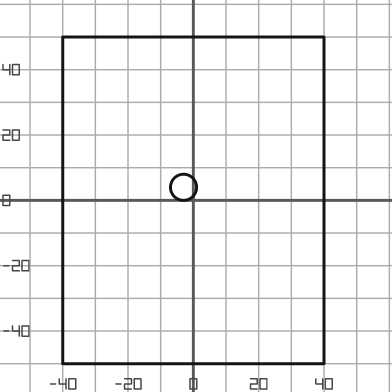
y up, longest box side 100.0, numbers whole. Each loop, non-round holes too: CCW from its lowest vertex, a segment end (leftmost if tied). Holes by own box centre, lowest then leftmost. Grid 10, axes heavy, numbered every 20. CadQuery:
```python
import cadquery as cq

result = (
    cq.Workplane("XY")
    .moveTo(-40.0, -50.0)
    .lineTo(40.0, -50.0)
    .lineTo(40.0, 50.0)
    .lineTo(-40.0, 50.0)
    .close()
    .moveTo(-3.0, 4.0)
    .circle(4.0)
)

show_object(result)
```